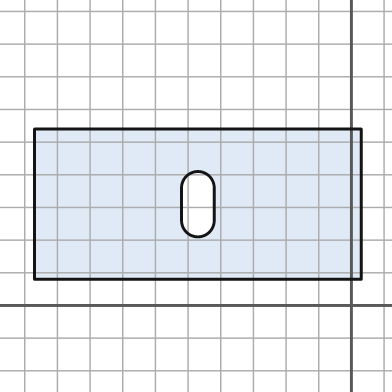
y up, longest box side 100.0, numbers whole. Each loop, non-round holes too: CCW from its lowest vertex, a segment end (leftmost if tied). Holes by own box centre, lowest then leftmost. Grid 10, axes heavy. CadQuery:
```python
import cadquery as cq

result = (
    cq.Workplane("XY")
    .moveTo(-97.0, 8.0)
    .lineTo(3.0, 8.0)
    .lineTo(3.0, 54.0)
    .lineTo(-97.0, 54.0)
    .close()
    .moveTo(-52.0, 26.0)
    .threePointArc((-47.0, 21.0), (-42.0, 26.0))
    .lineTo(-42.0, 36.0)
    .threePointArc((-47.0, 41.0), (-52.0, 36.0))
    .close()
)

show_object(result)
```